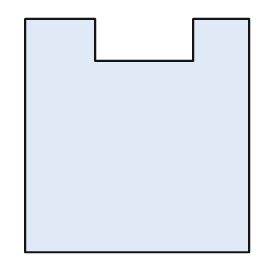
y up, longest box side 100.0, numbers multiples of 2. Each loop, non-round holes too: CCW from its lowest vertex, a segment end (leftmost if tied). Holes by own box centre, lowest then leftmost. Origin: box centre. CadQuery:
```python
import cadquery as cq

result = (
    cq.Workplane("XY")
    .moveTo(-48.0, -50.0)
    .lineTo(48.0, -50.0)
    .lineTo(48.0, 50.0)
    .lineTo(24.0, 50.0)
    .lineTo(24.0, 32.0)
    .lineTo(-18.0, 32.0)
    .lineTo(-18.0, 50.0)
    .lineTo(-48.0, 50.0)
    .close()
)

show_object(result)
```